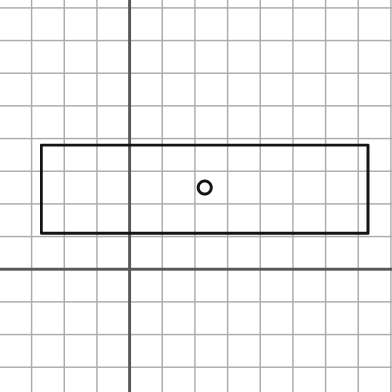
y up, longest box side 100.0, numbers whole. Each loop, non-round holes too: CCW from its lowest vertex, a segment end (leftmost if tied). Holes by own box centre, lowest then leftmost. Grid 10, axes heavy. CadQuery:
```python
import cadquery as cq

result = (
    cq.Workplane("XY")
    .moveTo(-27.0, 11.0)
    .lineTo(73.0, 11.0)
    .lineTo(73.0, 38.0)
    .lineTo(-27.0, 38.0)
    .close()
    .moveTo(23.0, 25.0)
    .circle(2.0)
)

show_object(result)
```